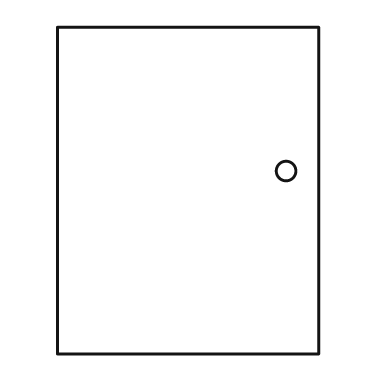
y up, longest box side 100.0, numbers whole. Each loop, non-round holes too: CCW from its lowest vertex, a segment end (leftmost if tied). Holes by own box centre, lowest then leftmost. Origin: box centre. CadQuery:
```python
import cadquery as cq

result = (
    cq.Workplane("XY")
    .moveTo(-40.0, -50.0)
    .lineTo(40.0, -50.0)
    .lineTo(40.0, 50.0)
    .lineTo(-40.0, 50.0)
    .close()
    .moveTo(30.0, 6.0)
    .circle(3.0)
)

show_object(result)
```